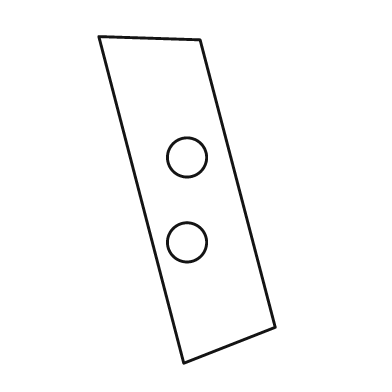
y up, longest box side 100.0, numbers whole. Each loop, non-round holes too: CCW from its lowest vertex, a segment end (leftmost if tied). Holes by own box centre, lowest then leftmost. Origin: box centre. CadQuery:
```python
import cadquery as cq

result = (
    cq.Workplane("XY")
    .moveTo(-1.0, -50.0)
    .lineTo(27.0, -39.0)
    .lineTo(4.0, 49.0)
    .lineTo(-27.0, 50.0)
    .close()
    .moveTo(0.0, -13.0)
    .circle(6.0)
    .moveTo(0.0, 13.0)
    .circle(6.0)
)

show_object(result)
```